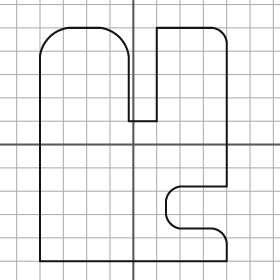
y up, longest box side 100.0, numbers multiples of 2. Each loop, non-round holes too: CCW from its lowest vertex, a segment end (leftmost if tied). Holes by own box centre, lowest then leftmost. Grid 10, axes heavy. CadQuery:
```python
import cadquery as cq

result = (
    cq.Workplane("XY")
    .moveTo(-40.0, -50.0)
    .lineTo(40.0, -50.0)
    .lineTo(40.0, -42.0)
    .threePointArc((38.0, -38.0), (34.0, -36.0))
    .lineTo(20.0, -36.0)
    .threePointArc((16.0, -34.0), (14.0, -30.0))
    .lineTo(14.0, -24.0)
    .threePointArc((16.0, -20.0), (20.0, -18.0))
    .lineTo(40.0, -18.0)
    .lineTo(40.0, 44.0)
    .threePointArc((38.0, 48.0), (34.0, 50.0))
    .lineTo(10.0, 50.0)
    .lineTo(10.0, 10.0)
    .lineTo(-2.0, 10.0)
    .lineTo(-2.0, 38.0)
    .threePointArc((-6.0, 46.0), (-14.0, 50.0))
    .lineTo(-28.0, 50.0)
    .threePointArc((-36.0, 46.0), (-40.0, 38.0))
    .close()
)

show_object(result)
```